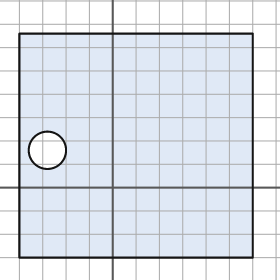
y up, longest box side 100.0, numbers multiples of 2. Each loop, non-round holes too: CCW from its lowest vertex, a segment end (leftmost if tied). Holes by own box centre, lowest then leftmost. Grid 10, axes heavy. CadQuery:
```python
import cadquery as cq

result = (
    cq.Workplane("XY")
    .moveTo(-40.0, -30.0)
    .lineTo(60.0, -30.0)
    .lineTo(60.0, 66.0)
    .lineTo(-40.0, 66.0)
    .close()
    .moveTo(-28.0, 16.0)
    .circle(8.0)
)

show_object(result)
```